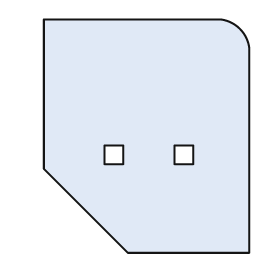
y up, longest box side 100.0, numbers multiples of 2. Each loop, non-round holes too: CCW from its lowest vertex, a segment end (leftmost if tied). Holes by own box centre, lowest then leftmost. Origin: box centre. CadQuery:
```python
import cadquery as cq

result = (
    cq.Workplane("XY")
    .moveTo(-8.0, -50.0)
    .lineTo(44.0, -50.0)
    .lineTo(44.0, 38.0)
    .threePointArc((40.0, 46.0), (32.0, 50.0))
    .lineTo(-44.0, 50.0)
    .lineTo(-44.0, -14.0)
    .close()
    .moveTo(-18.0, -12.0)
    .lineTo(-10.0, -12.0)
    .lineTo(-10.0, -4.0)
    .lineTo(-18.0, -4.0)
    .close()
    .moveTo(12.0, -12.0)
    .lineTo(20.0, -12.0)
    .lineTo(20.0, -4.0)
    .lineTo(12.0, -4.0)
    .close()
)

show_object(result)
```